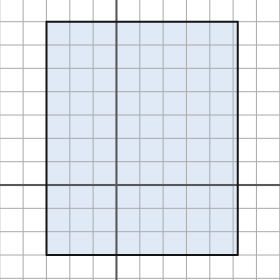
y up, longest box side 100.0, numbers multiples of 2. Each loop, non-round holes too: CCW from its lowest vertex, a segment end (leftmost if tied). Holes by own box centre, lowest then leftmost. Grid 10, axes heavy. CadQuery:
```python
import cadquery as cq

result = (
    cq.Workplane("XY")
    .moveTo(-30.0, -30.0)
    .lineTo(52.0, -30.0)
    .lineTo(52.0, 70.0)
    .lineTo(-30.0, 70.0)
    .close()
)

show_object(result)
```